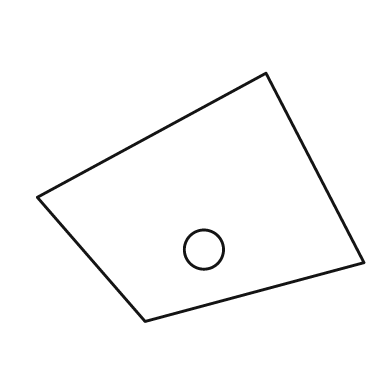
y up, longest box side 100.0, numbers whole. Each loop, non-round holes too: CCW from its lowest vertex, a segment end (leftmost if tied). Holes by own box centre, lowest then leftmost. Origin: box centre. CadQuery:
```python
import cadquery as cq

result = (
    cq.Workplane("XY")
    .moveTo(-17.0, -38.0)
    .lineTo(50.0, -20.0)
    .lineTo(20.0, 38.0)
    .lineTo(-50.0, 0.0)
    .close()
    .moveTo(1.0, -16.0)
    .circle(6.0)
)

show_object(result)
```